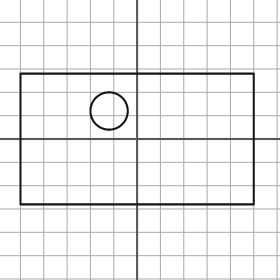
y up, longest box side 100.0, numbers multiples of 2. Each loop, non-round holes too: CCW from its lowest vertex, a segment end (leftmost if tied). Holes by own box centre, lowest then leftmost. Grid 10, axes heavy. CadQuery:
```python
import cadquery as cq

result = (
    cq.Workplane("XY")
    .moveTo(-50.0, -28.0)
    .lineTo(50.0, -28.0)
    .lineTo(50.0, 28.0)
    .lineTo(-50.0, 28.0)
    .close()
    .moveTo(-12.0, 12.0)
    .circle(8.0)
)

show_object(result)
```